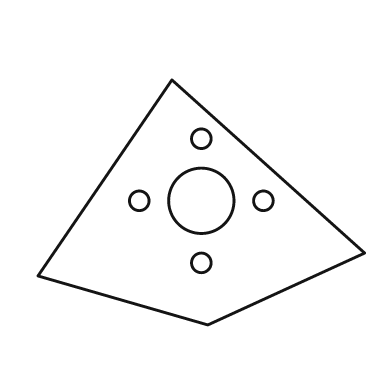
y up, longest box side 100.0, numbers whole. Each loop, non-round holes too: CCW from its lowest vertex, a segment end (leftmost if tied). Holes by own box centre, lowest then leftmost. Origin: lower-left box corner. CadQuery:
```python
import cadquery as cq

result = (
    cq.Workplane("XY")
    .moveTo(52.0, 0.0)
    .lineTo(100.0, 22.0)
    .lineTo(41.0, 75.0)
    .lineTo(0.0, 15.0)
    .close()
    .moveTo(50.0, 19.0)
    .circle(3.0)
    .moveTo(31.0, 38.0)
    .circle(3.0)
    .moveTo(50.0, 38.0)
    .circle(10.0)
    .moveTo(69.0, 38.0)
    .circle(3.0)
    .moveTo(50.0, 57.0)
    .circle(3.0)
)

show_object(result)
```